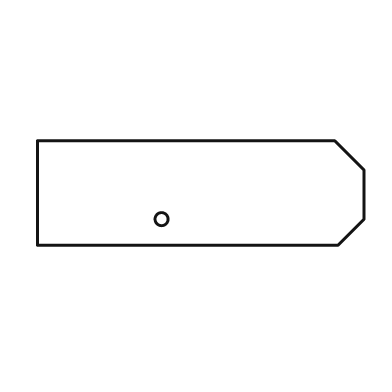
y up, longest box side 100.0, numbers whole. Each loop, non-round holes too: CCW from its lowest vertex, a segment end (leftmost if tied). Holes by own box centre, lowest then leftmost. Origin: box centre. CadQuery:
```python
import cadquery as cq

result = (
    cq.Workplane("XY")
    .moveTo(-50.0, -16.0)
    .lineTo(42.0, -16.0)
    .lineTo(50.0, -8.0)
    .lineTo(50.0, 7.0)
    .lineTo(41.0, 16.0)
    .lineTo(-50.0, 16.0)
    .close()
    .moveTo(-12.0, -8.0)
    .circle(2.0)
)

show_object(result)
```